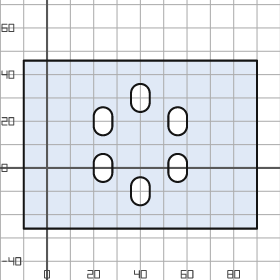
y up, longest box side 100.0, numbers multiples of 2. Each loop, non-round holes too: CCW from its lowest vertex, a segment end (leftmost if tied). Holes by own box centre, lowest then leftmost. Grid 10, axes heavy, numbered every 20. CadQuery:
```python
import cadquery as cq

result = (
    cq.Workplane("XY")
    .moveTo(-10.0, -26.0)
    .lineTo(90.0, -26.0)
    .lineTo(90.0, 46.0)
    .lineTo(-10.0, 46.0)
    .close()
    .moveTo(36.0, -12.0)
    .threePointArc((40.0, -16.0), (44.0, -12.0))
    .lineTo(44.0, -8.0)
    .threePointArc((40.0, -4.0), (36.0, -8.0))
    .close()
    .moveTo(20.0, -2.0)
    .threePointArc((24.0, -6.0), (28.0, -2.0))
    .lineTo(28.0, 2.0)
    .threePointArc((24.0, 6.0), (20.0, 2.0))
    .close()
    .moveTo(52.0, -2.0)
    .threePointArc((56.0, -6.0), (60.0, -2.0))
    .lineTo(60.0, 2.0)
    .threePointArc((56.0, 6.0), (52.0, 2.0))
    .close()
    .moveTo(20.0, 18.0)
    .threePointArc((24.0, 14.0), (28.0, 18.0))
    .lineTo(28.0, 22.0)
    .threePointArc((24.0, 26.0), (20.0, 22.0))
    .close()
    .moveTo(52.0, 18.0)
    .threePointArc((56.0, 14.0), (60.0, 18.0))
    .lineTo(60.0, 22.0)
    .threePointArc((56.0, 26.0), (52.0, 22.0))
    .close()
    .moveTo(36.0, 28.0)
    .threePointArc((40.0, 24.0), (44.0, 28.0))
    .lineTo(44.0, 32.0)
    .threePointArc((40.0, 36.0), (36.0, 32.0))
    .close()
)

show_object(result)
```